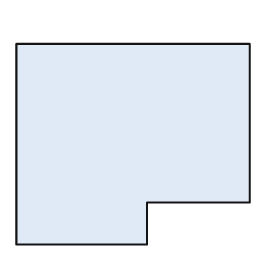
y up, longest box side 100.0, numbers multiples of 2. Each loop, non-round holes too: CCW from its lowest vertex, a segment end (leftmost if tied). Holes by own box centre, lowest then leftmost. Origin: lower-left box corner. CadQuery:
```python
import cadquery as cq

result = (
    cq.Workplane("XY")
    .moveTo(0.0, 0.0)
    .lineTo(56.0, 0.0)
    .lineTo(56.0, 18.0)
    .lineTo(100.0, 18.0)
    .lineTo(100.0, 86.0)
    .lineTo(0.0, 86.0)
    .close()
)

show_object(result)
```